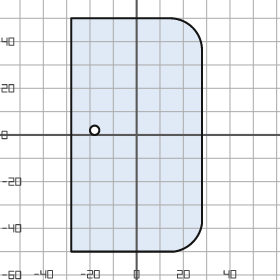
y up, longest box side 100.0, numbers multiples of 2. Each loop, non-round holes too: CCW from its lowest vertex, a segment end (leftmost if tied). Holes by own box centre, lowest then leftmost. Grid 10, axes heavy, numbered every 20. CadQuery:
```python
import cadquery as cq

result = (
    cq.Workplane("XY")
    .moveTo(-28.0, -50.0)
    .lineTo(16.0, -50.0)
    .threePointArc((24.0, -46.0), (28.0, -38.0))
    .lineTo(28.0, 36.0)
    .threePointArc((24.0, 46.0), (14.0, 50.0))
    .lineTo(-28.0, 50.0)
    .close()
    .moveTo(-18.0, 2.0)
    .circle(2.0)
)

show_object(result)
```